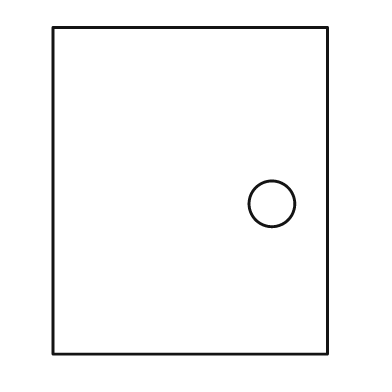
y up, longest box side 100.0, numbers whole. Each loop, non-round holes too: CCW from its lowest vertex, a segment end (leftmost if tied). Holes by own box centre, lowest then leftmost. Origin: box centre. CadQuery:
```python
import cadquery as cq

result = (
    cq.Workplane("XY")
    .moveTo(-42.0, -50.0)
    .lineTo(42.0, -50.0)
    .lineTo(42.0, 50.0)
    .lineTo(-42.0, 50.0)
    .close()
    .moveTo(25.0, -4.0)
    .circle(7.0)
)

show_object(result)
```